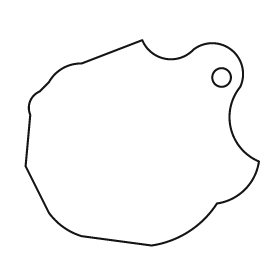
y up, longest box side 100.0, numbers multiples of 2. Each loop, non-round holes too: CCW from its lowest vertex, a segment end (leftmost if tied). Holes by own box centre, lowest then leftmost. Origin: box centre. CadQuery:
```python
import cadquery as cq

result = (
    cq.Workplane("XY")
    .moveTo(4.0, -44.0)
    .threePointArc((20.0, -38.0), (32.0, -26.0))
    .threePointArc((44.0, -20.0), (50.0, -8.0))
    .threePointArc((38.0, 6.0), (42.0, 24.0))
    .threePointArc((38.0, 40.0), (22.0, 40.0))
    .threePointArc((10.0, 36.0), (0.0, 44.0))
    .lineTo(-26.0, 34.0)
    .threePointArc((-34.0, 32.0), (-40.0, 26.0))
    .lineTo(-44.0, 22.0)
    .threePointArc((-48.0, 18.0), (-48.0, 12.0))
    .lineTo(-50.0, -10.0)
    .lineTo(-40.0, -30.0)
    .threePointArc((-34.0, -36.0), (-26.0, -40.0))
    .close()
    .moveTo(34.0, 28.0)
    .circle(4.0)
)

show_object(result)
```